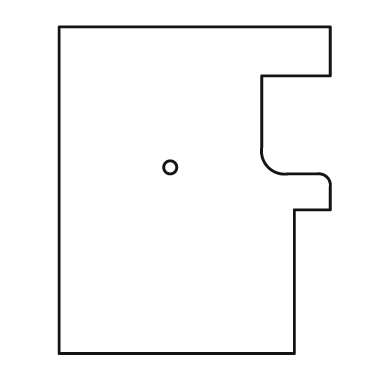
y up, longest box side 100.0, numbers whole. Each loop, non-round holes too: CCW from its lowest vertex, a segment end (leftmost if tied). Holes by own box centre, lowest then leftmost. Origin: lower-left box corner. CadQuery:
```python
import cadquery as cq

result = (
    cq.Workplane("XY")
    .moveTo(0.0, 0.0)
    .lineTo(72.0, 0.0)
    .lineTo(72.0, 44.0)
    .lineTo(83.0, 44.0)
    .lineTo(83.0, 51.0)
    .threePointArc((82.0, 54.0), (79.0, 55.0))
    .lineTo(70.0, 55.0)
    .threePointArc((64.0, 57.0), (62.0, 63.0))
    .lineTo(62.0, 85.0)
    .lineTo(83.0, 85.0)
    .lineTo(83.0, 100.0)
    .lineTo(0.0, 100.0)
    .close()
    .moveTo(34.0, 57.0)
    .circle(2.0)
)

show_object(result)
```